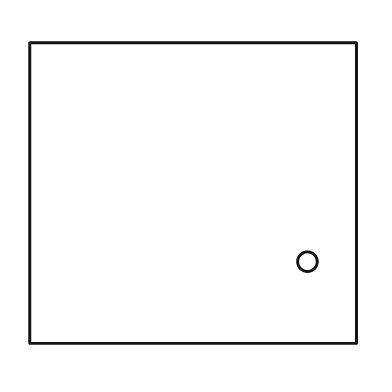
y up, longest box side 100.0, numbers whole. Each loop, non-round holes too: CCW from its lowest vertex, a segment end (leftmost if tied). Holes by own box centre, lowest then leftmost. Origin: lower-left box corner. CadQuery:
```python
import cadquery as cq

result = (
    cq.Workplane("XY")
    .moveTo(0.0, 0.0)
    .lineTo(100.0, 0.0)
    .lineTo(100.0, 92.0)
    .lineTo(0.0, 92.0)
    .close()
    .moveTo(85.0, 25.0)
    .circle(3.0)
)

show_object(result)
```